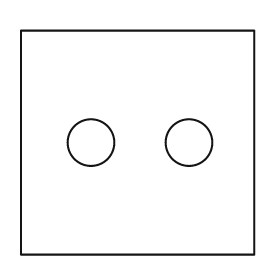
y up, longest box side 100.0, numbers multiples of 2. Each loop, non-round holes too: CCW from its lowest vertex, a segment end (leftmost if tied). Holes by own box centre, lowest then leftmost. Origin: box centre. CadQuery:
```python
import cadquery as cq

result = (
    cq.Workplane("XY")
    .moveTo(-50.0, -48.0)
    .lineTo(50.0, -48.0)
    .lineTo(50.0, 48.0)
    .lineTo(-50.0, 48.0)
    .close()
    .moveTo(-20.0, 0.0)
    .circle(10.0)
    .moveTo(22.0, 0.0)
    .circle(10.0)
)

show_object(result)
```